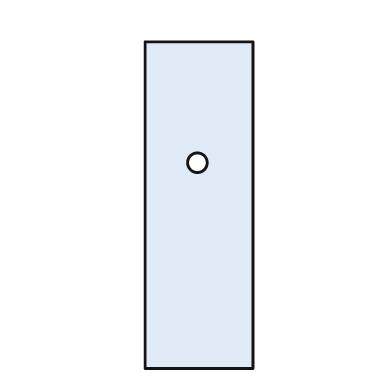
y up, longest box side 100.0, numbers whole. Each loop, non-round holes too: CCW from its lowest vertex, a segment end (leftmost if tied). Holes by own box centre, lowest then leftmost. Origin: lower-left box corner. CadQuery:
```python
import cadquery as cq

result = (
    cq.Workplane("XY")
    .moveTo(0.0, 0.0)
    .lineTo(33.0, 0.0)
    .lineTo(33.0, 100.0)
    .lineTo(0.0, 100.0)
    .close()
    .moveTo(16.0, 63.0)
    .circle(3.0)
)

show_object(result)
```